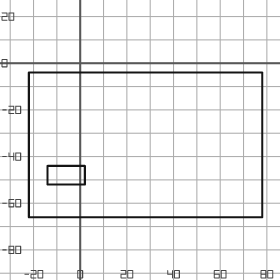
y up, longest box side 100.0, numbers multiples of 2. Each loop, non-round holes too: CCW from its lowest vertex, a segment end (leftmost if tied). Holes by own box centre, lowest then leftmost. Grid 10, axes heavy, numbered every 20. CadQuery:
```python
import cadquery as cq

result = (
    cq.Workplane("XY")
    .moveTo(-22.0, -66.0)
    .lineTo(78.0, -66.0)
    .lineTo(78.0, -4.0)
    .lineTo(-22.0, -4.0)
    .close()
    .moveTo(-14.0, -52.0)
    .lineTo(2.0, -52.0)
    .lineTo(2.0, -44.0)
    .lineTo(-14.0, -44.0)
    .close()
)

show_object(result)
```